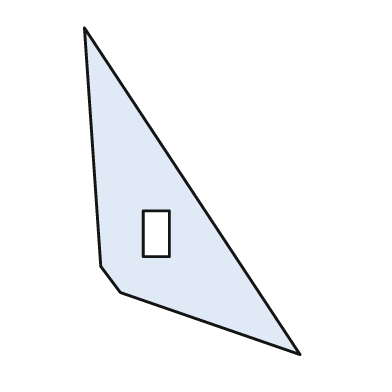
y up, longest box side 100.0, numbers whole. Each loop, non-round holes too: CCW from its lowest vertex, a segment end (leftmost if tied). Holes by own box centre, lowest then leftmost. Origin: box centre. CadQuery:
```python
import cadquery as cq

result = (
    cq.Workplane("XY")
    .moveTo(33.0, -50.0)
    .lineTo(-33.0, 50.0)
    .lineTo(-28.0, -23.0)
    .lineTo(-22.0, -31.0)
    .close()
    .moveTo(-15.0, -20.0)
    .lineTo(-7.0, -20.0)
    .lineTo(-7.0, -6.0)
    .lineTo(-15.0, -6.0)
    .close()
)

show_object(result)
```